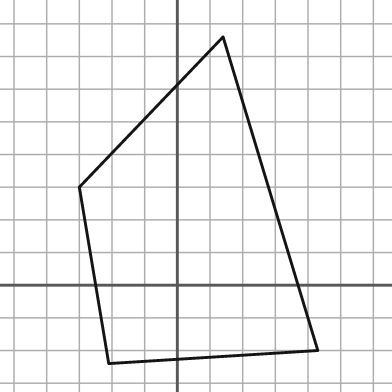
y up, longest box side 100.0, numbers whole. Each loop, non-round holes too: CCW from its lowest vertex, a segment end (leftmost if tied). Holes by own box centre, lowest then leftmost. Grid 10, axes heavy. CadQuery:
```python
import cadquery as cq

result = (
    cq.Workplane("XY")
    .moveTo(-21.0, -24.0)
    .lineTo(43.0, -20.0)
    .lineTo(14.0, 76.0)
    .lineTo(-30.0, 30.0)
    .close()
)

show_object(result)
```